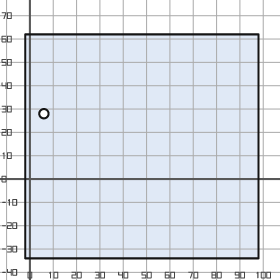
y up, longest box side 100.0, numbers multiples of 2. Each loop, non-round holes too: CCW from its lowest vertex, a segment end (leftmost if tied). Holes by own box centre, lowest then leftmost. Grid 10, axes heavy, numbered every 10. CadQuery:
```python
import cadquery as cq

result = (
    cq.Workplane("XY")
    .moveTo(-2.0, -34.0)
    .lineTo(98.0, -34.0)
    .lineTo(98.0, 62.0)
    .lineTo(-2.0, 62.0)
    .close()
    .moveTo(6.0, 28.0)
    .circle(2.0)
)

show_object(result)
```